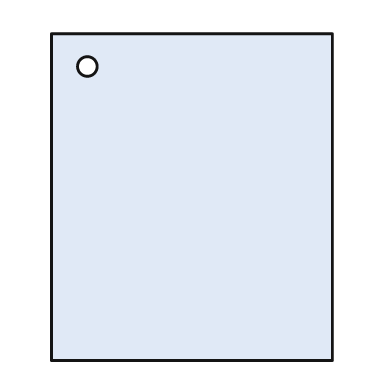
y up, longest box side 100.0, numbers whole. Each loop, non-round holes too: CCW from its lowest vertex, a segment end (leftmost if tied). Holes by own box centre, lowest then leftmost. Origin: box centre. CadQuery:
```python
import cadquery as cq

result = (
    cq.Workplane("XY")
    .moveTo(-43.0, -50.0)
    .lineTo(43.0, -50.0)
    .lineTo(43.0, 50.0)
    .lineTo(-43.0, 50.0)
    .close()
    .moveTo(-32.0, 40.0)
    .circle(3.0)
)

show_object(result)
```